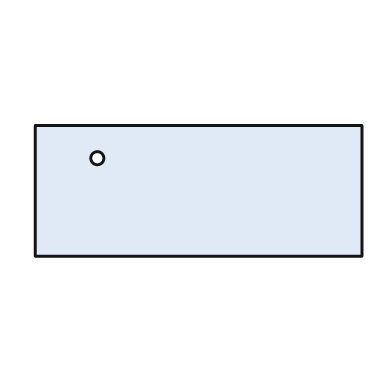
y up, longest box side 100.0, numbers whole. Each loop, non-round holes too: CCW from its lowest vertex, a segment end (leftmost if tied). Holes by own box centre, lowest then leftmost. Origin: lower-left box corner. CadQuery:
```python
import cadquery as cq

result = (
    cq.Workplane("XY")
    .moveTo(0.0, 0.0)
    .lineTo(100.0, 0.0)
    .lineTo(100.0, 40.0)
    .lineTo(0.0, 40.0)
    .close()
    .moveTo(19.0, 30.0)
    .circle(2.0)
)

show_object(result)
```